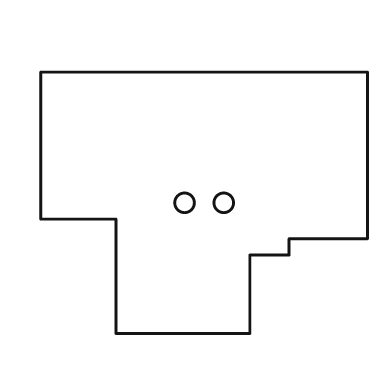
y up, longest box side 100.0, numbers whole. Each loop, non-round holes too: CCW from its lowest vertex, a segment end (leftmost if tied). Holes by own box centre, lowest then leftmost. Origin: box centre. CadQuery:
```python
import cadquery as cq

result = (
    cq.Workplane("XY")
    .moveTo(-27.0, -40.0)
    .lineTo(14.0, -40.0)
    .lineTo(14.0, -16.0)
    .lineTo(26.0, -16.0)
    .lineTo(26.0, -11.0)
    .lineTo(50.0, -11.0)
    .lineTo(50.0, 40.0)
    .lineTo(-50.0, 40.0)
    .lineTo(-50.0, -5.0)
    .lineTo(-27.0, -5.0)
    .close()
    .moveTo(-6.0, 0.0)
    .circle(3.0)
    .moveTo(6.0, 0.0)
    .circle(3.0)
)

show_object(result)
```